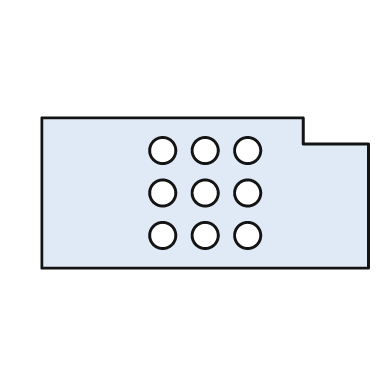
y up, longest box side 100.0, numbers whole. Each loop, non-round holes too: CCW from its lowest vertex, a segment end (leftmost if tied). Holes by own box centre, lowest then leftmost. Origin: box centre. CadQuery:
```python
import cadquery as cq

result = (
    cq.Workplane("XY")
    .moveTo(-50.0, -23.0)
    .lineTo(50.0, -23.0)
    .lineTo(50.0, 15.0)
    .lineTo(30.0, 15.0)
    .lineTo(30.0, 23.0)
    .lineTo(-50.0, 23.0)
    .close()
    .moveTo(-13.0, -13.0)
    .circle(4.0)
    .moveTo(0.0, -13.0)
    .circle(4.0)
    .moveTo(13.0, -13.0)
    .circle(4.0)
    .moveTo(-13.0, 0.0)
    .circle(4.0)
    .moveTo(0.0, 0.0)
    .circle(4.0)
    .moveTo(13.0, 0.0)
    .circle(4.0)
    .moveTo(-13.0, 13.0)
    .circle(4.0)
    .moveTo(0.0, 13.0)
    .circle(4.0)
    .moveTo(13.0, 13.0)
    .circle(4.0)
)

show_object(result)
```